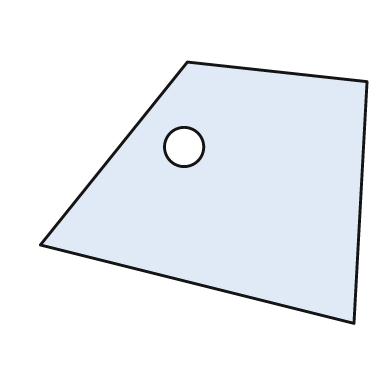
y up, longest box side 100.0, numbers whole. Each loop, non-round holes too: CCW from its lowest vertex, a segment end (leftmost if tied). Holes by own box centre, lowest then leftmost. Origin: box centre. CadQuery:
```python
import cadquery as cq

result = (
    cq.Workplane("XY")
    .moveTo(46.0, -40.0)
    .lineTo(50.0, 34.0)
    .lineTo(-5.0, 40.0)
    .lineTo(-50.0, -16.0)
    .close()
    .moveTo(-6.0, 14.0)
    .circle(6.0)
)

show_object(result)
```